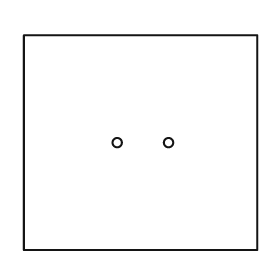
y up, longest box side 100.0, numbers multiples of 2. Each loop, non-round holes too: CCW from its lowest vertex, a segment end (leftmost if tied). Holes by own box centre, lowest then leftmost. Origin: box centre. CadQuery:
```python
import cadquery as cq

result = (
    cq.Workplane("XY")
    .moveTo(-50.0, -46.0)
    .lineTo(50.0, -46.0)
    .lineTo(50.0, 46.0)
    .lineTo(-50.0, 46.0)
    .close()
    .moveTo(-10.0, 0.0)
    .circle(2.0)
    .moveTo(12.0, 0.0)
    .circle(2.0)
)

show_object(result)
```